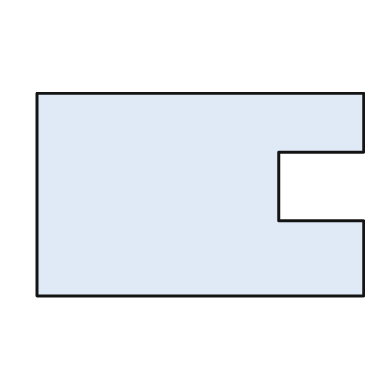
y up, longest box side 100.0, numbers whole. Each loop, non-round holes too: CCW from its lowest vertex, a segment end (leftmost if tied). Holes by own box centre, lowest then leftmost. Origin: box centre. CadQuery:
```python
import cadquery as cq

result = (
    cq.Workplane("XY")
    .moveTo(-50.0, -31.0)
    .lineTo(50.0, -31.0)
    .lineTo(50.0, -8.0)
    .lineTo(24.0, -8.0)
    .lineTo(24.0, 13.0)
    .lineTo(50.0, 13.0)
    .lineTo(50.0, 31.0)
    .lineTo(-50.0, 31.0)
    .close()
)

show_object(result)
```